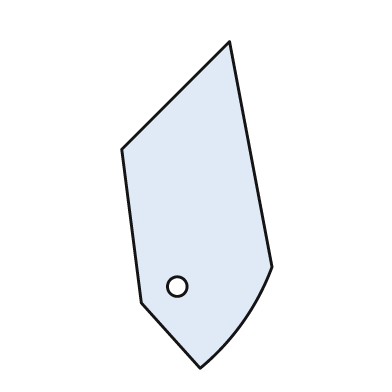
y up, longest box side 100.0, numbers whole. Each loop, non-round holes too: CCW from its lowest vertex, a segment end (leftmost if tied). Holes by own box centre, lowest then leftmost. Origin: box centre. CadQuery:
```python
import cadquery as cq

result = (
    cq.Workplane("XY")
    .moveTo(1.0, -50.0)
    .threePointArc((14.0, -36.0), (23.0, -19.0))
    .lineTo(10.0, 50.0)
    .lineTo(-23.0, 17.0)
    .lineTo(-17.0, -30.0)
    .close()
    .moveTo(-6.0, -25.0)
    .circle(3.0)
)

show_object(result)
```